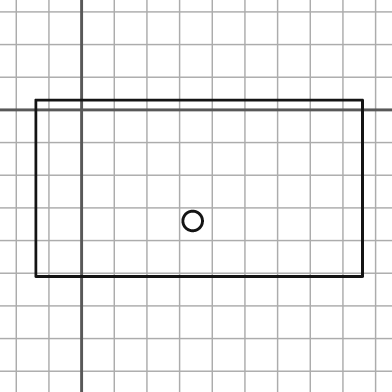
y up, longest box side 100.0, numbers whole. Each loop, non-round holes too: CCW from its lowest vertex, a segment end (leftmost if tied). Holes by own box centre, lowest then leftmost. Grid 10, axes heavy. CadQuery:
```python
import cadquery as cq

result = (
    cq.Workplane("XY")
    .moveTo(-14.0, -51.0)
    .lineTo(86.0, -51.0)
    .lineTo(86.0, 3.0)
    .lineTo(-14.0, 3.0)
    .close()
    .moveTo(34.0, -34.0)
    .circle(3.0)
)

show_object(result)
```